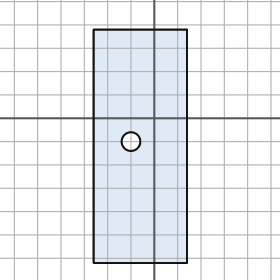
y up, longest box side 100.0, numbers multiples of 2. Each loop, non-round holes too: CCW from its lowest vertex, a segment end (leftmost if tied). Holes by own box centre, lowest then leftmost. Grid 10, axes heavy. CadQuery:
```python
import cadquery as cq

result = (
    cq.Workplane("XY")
    .moveTo(-26.0, -62.0)
    .lineTo(14.0, -62.0)
    .lineTo(14.0, 38.0)
    .lineTo(-26.0, 38.0)
    .close()
    .moveTo(-10.0, -10.0)
    .circle(4.0)
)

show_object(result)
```